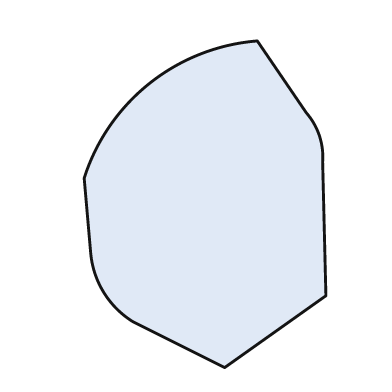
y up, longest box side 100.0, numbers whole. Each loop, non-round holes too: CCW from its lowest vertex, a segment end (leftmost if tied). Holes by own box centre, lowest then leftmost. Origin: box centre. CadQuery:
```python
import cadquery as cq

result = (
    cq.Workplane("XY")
    .moveTo(6.0, -50.0)
    .lineTo(37.0, -28.0)
    .lineTo(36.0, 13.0)
    .threePointArc((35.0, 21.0), (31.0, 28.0))
    .lineTo(16.0, 50.0)
    .threePointArc((-17.0, 37.0), (-37.0, 8.0))
    .lineTo(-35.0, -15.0)
    .threePointArc((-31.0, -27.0), (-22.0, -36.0))
    .close()
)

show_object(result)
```